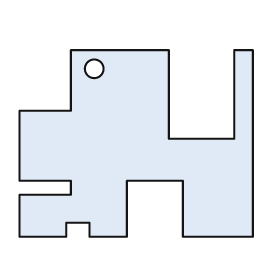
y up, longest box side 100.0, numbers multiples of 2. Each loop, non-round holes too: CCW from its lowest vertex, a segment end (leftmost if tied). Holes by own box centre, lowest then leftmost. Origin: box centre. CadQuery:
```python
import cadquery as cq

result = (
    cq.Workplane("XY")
    .moveTo(-50.0, -40.0)
    .lineTo(-30.0, -40.0)
    .lineTo(-30.0, -34.0)
    .lineTo(-20.0, -34.0)
    .lineTo(-20.0, -40.0)
    .lineTo(-4.0, -40.0)
    .lineTo(-4.0, -16.0)
    .lineTo(20.0, -16.0)
    .lineTo(20.0, -40.0)
    .lineTo(50.0, -40.0)
    .lineTo(50.0, 40.0)
    .lineTo(42.0, 40.0)
    .lineTo(42.0, 2.0)
    .lineTo(14.0, 2.0)
    .lineTo(14.0, 40.0)
    .lineTo(-28.0, 40.0)
    .lineTo(-28.0, 14.0)
    .lineTo(-50.0, 14.0)
    .lineTo(-50.0, -16.0)
    .lineTo(-28.0, -16.0)
    .lineTo(-28.0, -22.0)
    .lineTo(-50.0, -22.0)
    .close()
    .moveTo(-18.0, 32.0)
    .circle(4.0)
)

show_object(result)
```